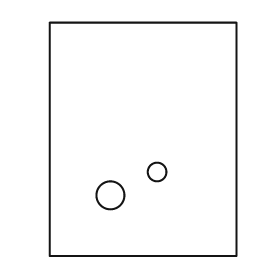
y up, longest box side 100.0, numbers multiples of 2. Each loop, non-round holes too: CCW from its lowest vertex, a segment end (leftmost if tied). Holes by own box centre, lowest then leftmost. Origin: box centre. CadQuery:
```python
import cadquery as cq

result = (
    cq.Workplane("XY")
    .moveTo(-40.0, -50.0)
    .lineTo(40.0, -50.0)
    .lineTo(40.0, 50.0)
    .lineTo(-40.0, 50.0)
    .close()
    .moveTo(-14.0, -24.0)
    .circle(6.0)
    .moveTo(6.0, -14.0)
    .circle(4.0)
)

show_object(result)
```